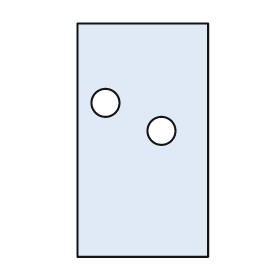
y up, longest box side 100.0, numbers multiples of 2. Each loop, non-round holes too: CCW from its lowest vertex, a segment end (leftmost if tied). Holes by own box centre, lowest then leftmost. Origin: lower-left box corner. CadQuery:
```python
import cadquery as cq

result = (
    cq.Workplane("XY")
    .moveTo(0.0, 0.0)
    .lineTo(56.0, 0.0)
    .lineTo(56.0, 100.0)
    .lineTo(0.0, 100.0)
    .close()
    .moveTo(36.0, 54.0)
    .circle(6.0)
    .moveTo(12.0, 66.0)
    .circle(6.0)
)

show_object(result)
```